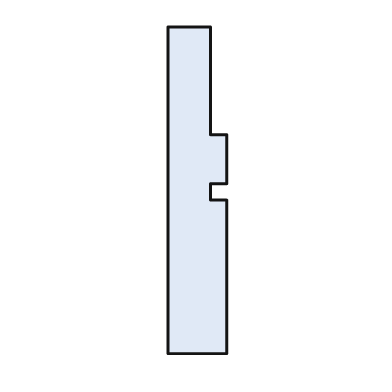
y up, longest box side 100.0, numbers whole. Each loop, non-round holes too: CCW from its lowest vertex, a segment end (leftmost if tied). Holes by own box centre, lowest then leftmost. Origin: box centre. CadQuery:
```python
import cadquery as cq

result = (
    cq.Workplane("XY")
    .moveTo(-9.0, -50.0)
    .lineTo(9.0, -50.0)
    .lineTo(9.0, -3.0)
    .lineTo(4.0, -3.0)
    .lineTo(4.0, 2.0)
    .lineTo(9.0, 2.0)
    .lineTo(9.0, 17.0)
    .lineTo(4.0, 17.0)
    .lineTo(4.0, 50.0)
    .lineTo(-9.0, 50.0)
    .close()
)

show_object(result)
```